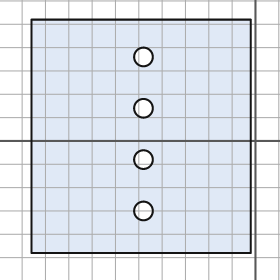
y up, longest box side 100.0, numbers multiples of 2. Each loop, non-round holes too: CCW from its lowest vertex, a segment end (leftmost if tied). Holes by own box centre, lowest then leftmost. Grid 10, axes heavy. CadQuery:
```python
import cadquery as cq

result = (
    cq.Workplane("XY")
    .moveTo(-96.0, -48.0)
    .lineTo(-2.0, -48.0)
    .lineTo(-2.0, 52.0)
    .lineTo(-96.0, 52.0)
    .close()
    .moveTo(-48.0, -30.0)
    .circle(4.0)
    .moveTo(-48.0, -8.0)
    .circle(4.0)
    .moveTo(-48.0, 14.0)
    .circle(4.0)
    .moveTo(-48.0, 36.0)
    .circle(4.0)
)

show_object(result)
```